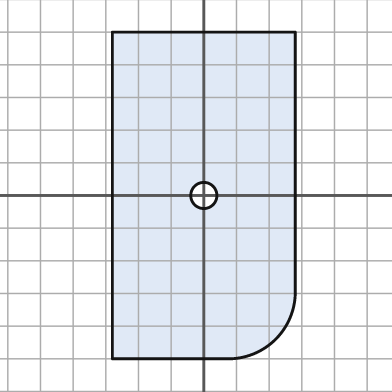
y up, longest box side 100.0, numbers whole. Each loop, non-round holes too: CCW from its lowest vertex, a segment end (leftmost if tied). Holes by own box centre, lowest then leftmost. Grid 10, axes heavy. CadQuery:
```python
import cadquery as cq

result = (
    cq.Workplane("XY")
    .moveTo(-28.0, -50.0)
    .lineTo(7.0, -50.0)
    .threePointArc((22.0, -44.0), (28.0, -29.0))
    .lineTo(28.0, 50.0)
    .lineTo(-28.0, 50.0)
    .close()
    .moveTo(0.0, 0.0)
    .circle(4.0)
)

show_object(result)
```